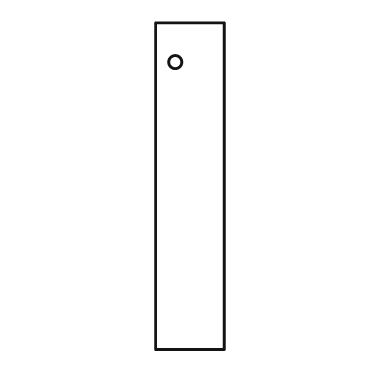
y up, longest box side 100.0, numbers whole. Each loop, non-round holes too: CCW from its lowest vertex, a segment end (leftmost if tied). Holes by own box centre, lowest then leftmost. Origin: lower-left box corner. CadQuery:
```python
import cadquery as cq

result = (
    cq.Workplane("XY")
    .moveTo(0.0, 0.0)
    .lineTo(21.0, 0.0)
    .lineTo(21.0, 100.0)
    .lineTo(0.0, 100.0)
    .close()
    .moveTo(6.0, 88.0)
    .circle(2.0)
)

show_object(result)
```